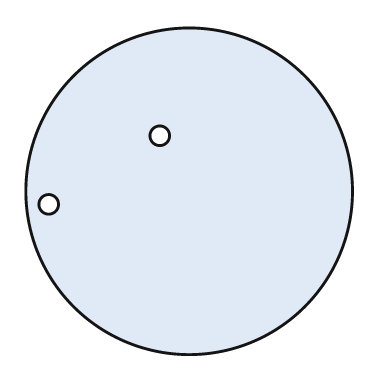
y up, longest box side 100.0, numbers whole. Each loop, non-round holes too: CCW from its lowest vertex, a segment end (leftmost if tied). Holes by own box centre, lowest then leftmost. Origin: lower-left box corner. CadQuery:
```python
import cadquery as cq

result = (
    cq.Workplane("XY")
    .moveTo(50.0, 50.0)
    .circle(50.0)
    .moveTo(7.0, 46.0)
    .circle(3.0)
    .moveTo(41.0, 67.0)
    .circle(3.0)
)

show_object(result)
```